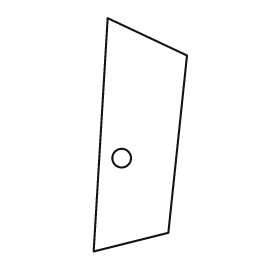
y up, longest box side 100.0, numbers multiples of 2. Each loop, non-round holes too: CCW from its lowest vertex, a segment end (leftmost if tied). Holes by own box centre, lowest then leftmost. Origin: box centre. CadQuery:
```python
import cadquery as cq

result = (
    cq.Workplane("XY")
    .moveTo(-20.0, -50.0)
    .lineTo(12.0, -42.0)
    .lineTo(20.0, 34.0)
    .lineTo(-14.0, 50.0)
    .close()
    .moveTo(-8.0, -10.0)
    .circle(4.0)
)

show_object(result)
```